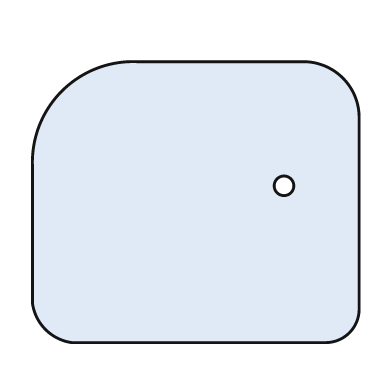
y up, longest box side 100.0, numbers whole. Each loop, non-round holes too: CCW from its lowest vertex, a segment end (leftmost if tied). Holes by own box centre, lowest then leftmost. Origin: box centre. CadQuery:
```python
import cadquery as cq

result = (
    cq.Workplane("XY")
    .moveTo(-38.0, -43.0)
    .lineTo(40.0, -43.0)
    .threePointArc((47.0, -40.0), (50.0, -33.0))
    .lineTo(50.0, 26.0)
    .threePointArc((45.0, 38.0), (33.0, 43.0))
    .lineTo(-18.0, 43.0)
    .threePointArc((-41.0, 34.0), (-50.0, 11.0))
    .lineTo(-50.0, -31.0)
    .threePointArc((-46.0, -39.0), (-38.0, -43.0))
    .close()
    .moveTo(27.0, 5.0)
    .circle(3.0)
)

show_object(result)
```